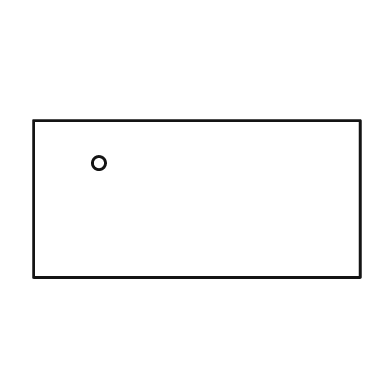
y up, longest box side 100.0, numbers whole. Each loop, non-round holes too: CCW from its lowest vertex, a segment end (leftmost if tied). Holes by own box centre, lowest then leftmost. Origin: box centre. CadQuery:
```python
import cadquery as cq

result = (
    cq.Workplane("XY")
    .moveTo(-50.0, -24.0)
    .lineTo(50.0, -24.0)
    .lineTo(50.0, 24.0)
    .lineTo(-50.0, 24.0)
    .close()
    .moveTo(-30.0, 11.0)
    .circle(2.0)
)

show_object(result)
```